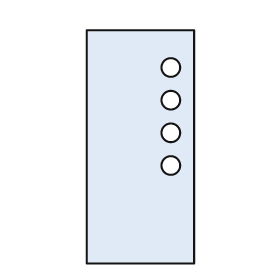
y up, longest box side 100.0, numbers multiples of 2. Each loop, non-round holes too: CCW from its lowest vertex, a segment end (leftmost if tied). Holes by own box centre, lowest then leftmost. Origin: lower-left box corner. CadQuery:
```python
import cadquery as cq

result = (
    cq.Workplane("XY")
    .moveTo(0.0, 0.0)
    .lineTo(46.0, 0.0)
    .lineTo(46.0, 100.0)
    .lineTo(0.0, 100.0)
    .close()
    .moveTo(36.0, 42.0)
    .circle(4.0)
    .moveTo(36.0, 56.0)
    .circle(4.0)
    .moveTo(36.0, 70.0)
    .circle(4.0)
    .moveTo(36.0, 84.0)
    .circle(4.0)
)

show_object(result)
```